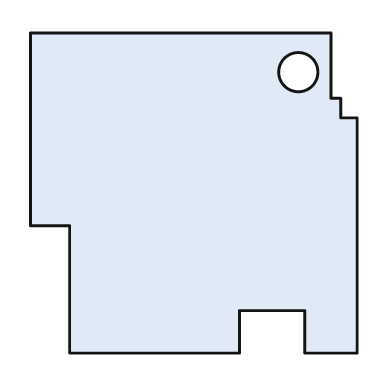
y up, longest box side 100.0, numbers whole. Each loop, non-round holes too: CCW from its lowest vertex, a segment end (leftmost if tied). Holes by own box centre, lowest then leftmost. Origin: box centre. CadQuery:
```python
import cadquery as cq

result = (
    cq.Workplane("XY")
    .moveTo(-38.0, -49.0)
    .lineTo(14.0, -49.0)
    .lineTo(14.0, -36.0)
    .lineTo(34.0, -36.0)
    .lineTo(34.0, -49.0)
    .lineTo(50.0, -49.0)
    .lineTo(50.0, 23.0)
    .lineTo(45.0, 23.0)
    .lineTo(45.0, 29.0)
    .lineTo(42.0, 29.0)
    .lineTo(42.0, 49.0)
    .lineTo(-50.0, 49.0)
    .lineTo(-50.0, -10.0)
    .lineTo(-38.0, -10.0)
    .close()
    .moveTo(32.0, 37.0)
    .circle(6.0)
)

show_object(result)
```